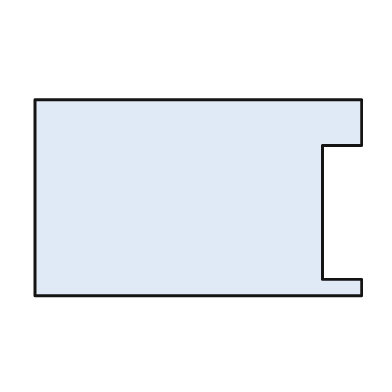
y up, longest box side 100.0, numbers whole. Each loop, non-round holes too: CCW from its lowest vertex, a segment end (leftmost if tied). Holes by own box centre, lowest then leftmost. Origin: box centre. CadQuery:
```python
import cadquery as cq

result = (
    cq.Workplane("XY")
    .moveTo(-50.0, -30.0)
    .lineTo(50.0, -30.0)
    .lineTo(50.0, -25.0)
    .lineTo(38.0, -25.0)
    .lineTo(38.0, 16.0)
    .lineTo(50.0, 16.0)
    .lineTo(50.0, 30.0)
    .lineTo(-50.0, 30.0)
    .close()
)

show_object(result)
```